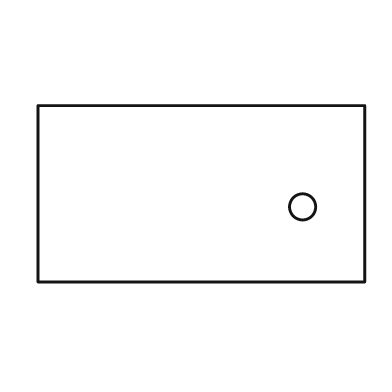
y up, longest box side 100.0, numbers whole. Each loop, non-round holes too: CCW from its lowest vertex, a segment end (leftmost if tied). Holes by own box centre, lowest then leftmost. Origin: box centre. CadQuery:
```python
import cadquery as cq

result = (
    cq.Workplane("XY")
    .moveTo(-50.0, -27.0)
    .lineTo(50.0, -27.0)
    .lineTo(50.0, 27.0)
    .lineTo(-50.0, 27.0)
    .close()
    .moveTo(31.0, -4.0)
    .circle(4.0)
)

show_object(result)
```